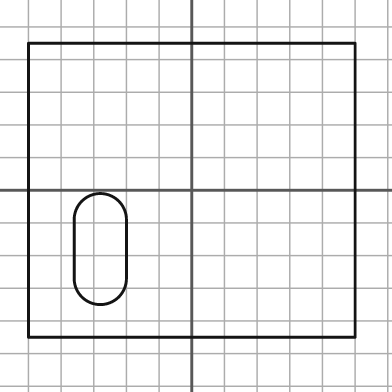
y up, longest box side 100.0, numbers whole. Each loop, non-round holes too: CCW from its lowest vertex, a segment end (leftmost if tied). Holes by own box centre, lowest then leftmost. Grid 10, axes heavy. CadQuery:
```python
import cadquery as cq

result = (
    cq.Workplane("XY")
    .moveTo(-50.0, -45.0)
    .lineTo(50.0, -45.0)
    .lineTo(50.0, 45.0)
    .lineTo(-50.0, 45.0)
    .close()
    .moveTo(-36.0, -27.0)
    .threePointArc((-28.0, -35.0), (-20.0, -27.0))
    .lineTo(-20.0, -9.0)
    .threePointArc((-28.0, -1.0), (-36.0, -9.0))
    .close()
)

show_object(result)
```